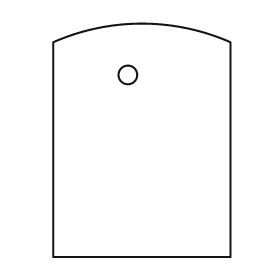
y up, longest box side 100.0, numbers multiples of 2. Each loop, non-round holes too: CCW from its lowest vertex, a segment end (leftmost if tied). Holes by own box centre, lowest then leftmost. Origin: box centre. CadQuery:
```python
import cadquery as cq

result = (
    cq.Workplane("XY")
    .moveTo(-38.0, -50.0)
    .lineTo(38.0, -50.0)
    .lineTo(38.0, 42.0)
    .threePointArc((0.0, 50.0), (-38.0, 42.0))
    .close()
    .moveTo(-6.0, 28.0)
    .circle(4.0)
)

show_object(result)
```